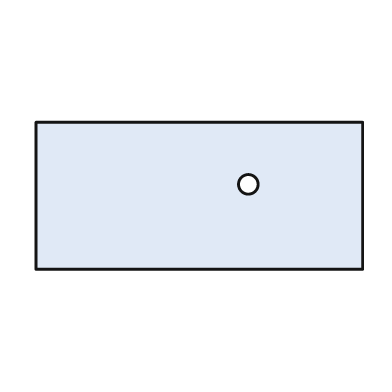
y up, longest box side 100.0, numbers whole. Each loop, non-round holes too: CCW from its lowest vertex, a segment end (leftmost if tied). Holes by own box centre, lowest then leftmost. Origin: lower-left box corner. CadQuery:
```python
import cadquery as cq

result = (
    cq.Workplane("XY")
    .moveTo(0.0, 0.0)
    .lineTo(100.0, 0.0)
    .lineTo(100.0, 45.0)
    .lineTo(0.0, 45.0)
    .close()
    .moveTo(65.0, 26.0)
    .circle(3.0)
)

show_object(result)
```